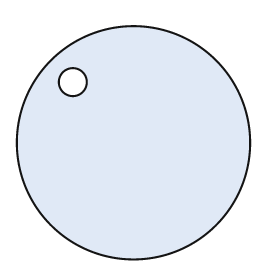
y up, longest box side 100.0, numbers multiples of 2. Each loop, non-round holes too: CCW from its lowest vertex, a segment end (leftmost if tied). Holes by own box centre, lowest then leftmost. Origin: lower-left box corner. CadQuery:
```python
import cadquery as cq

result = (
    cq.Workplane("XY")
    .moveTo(50.0, 50.0)
    .circle(50.0)
    .moveTo(24.0, 76.0)
    .circle(6.0)
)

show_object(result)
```